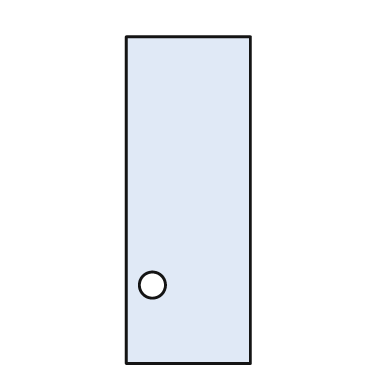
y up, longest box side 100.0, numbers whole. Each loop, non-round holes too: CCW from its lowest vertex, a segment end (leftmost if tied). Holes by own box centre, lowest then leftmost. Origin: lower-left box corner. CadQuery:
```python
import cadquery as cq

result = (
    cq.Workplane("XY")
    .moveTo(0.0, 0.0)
    .lineTo(38.0, 0.0)
    .lineTo(38.0, 100.0)
    .lineTo(0.0, 100.0)
    .close()
    .moveTo(8.0, 24.0)
    .circle(4.0)
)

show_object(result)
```